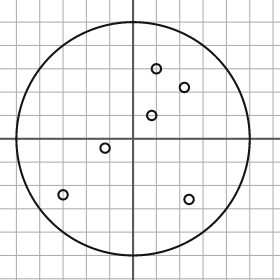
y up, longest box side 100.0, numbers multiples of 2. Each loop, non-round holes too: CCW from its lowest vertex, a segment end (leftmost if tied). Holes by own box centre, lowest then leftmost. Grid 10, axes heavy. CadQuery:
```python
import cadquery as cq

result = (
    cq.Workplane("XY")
    .moveTo(0.0, 0.0)
    .circle(50.0)
    .moveTo(24.0, -26.0)
    .circle(2.0)
    .moveTo(-30.0, -24.0)
    .circle(2.0)
    .moveTo(-12.0, -4.0)
    .circle(2.0)
    .moveTo(8.0, 10.0)
    .circle(2.0)
    .moveTo(22.0, 22.0)
    .circle(2.0)
    .moveTo(10.0, 30.0)
    .circle(2.0)
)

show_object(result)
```